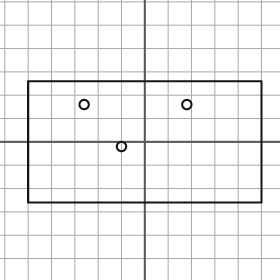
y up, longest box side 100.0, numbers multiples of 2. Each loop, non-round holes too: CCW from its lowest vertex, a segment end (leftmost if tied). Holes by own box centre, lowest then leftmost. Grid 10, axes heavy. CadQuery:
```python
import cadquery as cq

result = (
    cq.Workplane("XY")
    .moveTo(-50.0, -26.0)
    .lineTo(50.0, -26.0)
    .lineTo(50.0, 26.0)
    .lineTo(-50.0, 26.0)
    .close()
    .moveTo(-10.0, -2.0)
    .circle(2.0)
    .moveTo(-26.0, 16.0)
    .circle(2.0)
    .moveTo(18.0, 16.0)
    .circle(2.0)
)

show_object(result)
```